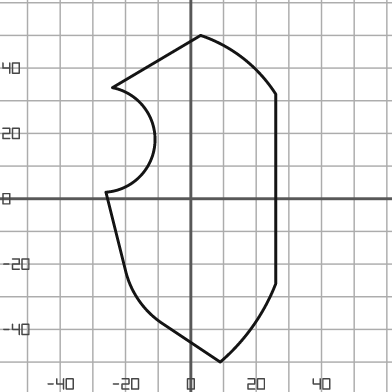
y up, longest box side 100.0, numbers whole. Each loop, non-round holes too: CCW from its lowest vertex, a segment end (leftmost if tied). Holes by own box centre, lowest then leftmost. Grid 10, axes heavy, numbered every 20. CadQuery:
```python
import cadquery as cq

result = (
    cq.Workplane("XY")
    .moveTo(9.0, -50.0)
    .threePointArc((19.0, -39.0), (26.0, -26.0))
    .lineTo(26.0, 32.0)
    .threePointArc((16.0, 43.0), (3.0, 50.0))
    .lineTo(-24.0, 34.0)
    .threePointArc((-11.0, 17.0), (-26.0, 2.0))
    .lineTo(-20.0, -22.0)
    .threePointArc((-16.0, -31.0), (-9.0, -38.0))
    .close()
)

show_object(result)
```